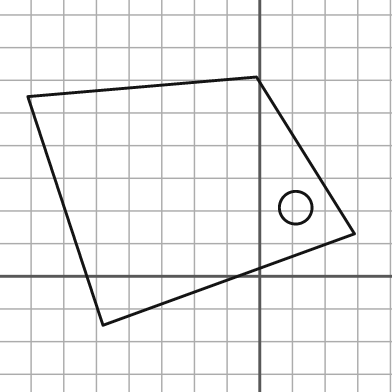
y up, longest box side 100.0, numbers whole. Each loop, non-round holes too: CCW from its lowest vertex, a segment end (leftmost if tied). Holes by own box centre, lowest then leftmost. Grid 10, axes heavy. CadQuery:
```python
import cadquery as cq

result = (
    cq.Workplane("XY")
    .moveTo(-48.0, -15.0)
    .lineTo(29.0, 13.0)
    .lineTo(-1.0, 61.0)
    .lineTo(-71.0, 55.0)
    .close()
    .moveTo(11.0, 21.0)
    .circle(5.0)
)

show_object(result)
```